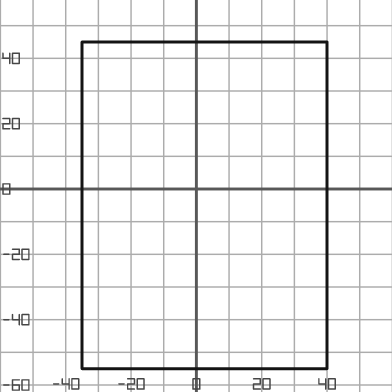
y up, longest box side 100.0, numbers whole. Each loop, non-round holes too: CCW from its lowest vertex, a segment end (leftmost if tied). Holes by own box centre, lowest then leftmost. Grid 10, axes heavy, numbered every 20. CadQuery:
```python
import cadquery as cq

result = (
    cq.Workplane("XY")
    .moveTo(-35.0, -55.0)
    .lineTo(40.0, -55.0)
    .lineTo(40.0, 45.0)
    .lineTo(-35.0, 45.0)
    .close()
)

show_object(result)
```